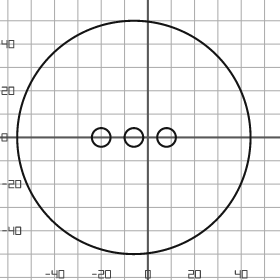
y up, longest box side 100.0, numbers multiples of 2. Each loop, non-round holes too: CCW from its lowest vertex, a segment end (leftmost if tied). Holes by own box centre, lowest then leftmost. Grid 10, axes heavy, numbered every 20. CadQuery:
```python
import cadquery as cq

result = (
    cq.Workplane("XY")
    .moveTo(-6.0, 0.0)
    .circle(50.0)
    .moveTo(-20.0, 0.0)
    .circle(4.0)
    .moveTo(-6.0, 0.0)
    .circle(4.0)
    .moveTo(8.0, 0.0)
    .circle(4.0)
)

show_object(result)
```